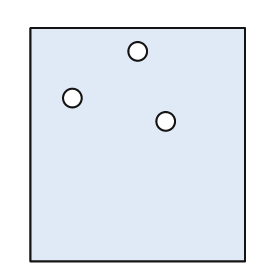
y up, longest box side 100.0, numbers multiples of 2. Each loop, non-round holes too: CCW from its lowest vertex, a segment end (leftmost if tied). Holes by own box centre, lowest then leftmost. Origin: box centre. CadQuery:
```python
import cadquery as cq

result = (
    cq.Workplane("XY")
    .moveTo(-46.0, -50.0)
    .lineTo(46.0, -50.0)
    .lineTo(46.0, 50.0)
    .lineTo(-46.0, 50.0)
    .close()
    .moveTo(12.0, 10.0)
    .circle(4.0)
    .moveTo(-28.0, 20.0)
    .circle(4.0)
    .moveTo(0.0, 40.0)
    .circle(4.0)
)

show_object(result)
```